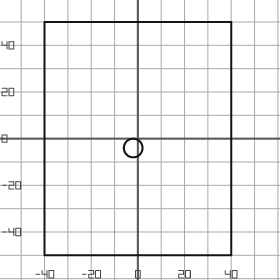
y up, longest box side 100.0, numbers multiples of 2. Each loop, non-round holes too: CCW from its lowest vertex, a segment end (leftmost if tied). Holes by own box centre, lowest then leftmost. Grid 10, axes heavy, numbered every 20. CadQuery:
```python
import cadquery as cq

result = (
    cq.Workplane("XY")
    .moveTo(-40.0, -50.0)
    .lineTo(40.0, -50.0)
    .lineTo(40.0, 50.0)
    .lineTo(-40.0, 50.0)
    .close()
    .moveTo(-2.0, -4.0)
    .circle(4.0)
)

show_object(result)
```